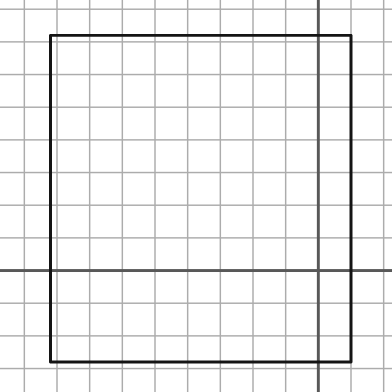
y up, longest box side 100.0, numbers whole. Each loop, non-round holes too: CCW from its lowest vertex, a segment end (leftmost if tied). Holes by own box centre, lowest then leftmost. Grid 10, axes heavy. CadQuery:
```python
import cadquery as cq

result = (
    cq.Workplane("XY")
    .moveTo(-82.0, -28.0)
    .lineTo(10.0, -28.0)
    .lineTo(10.0, 72.0)
    .lineTo(-82.0, 72.0)
    .close()
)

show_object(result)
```